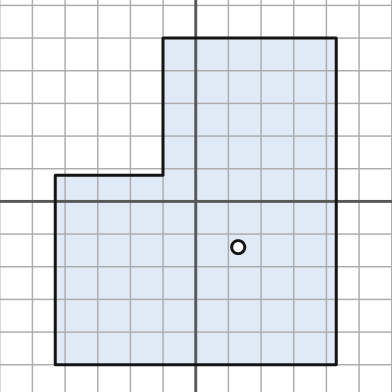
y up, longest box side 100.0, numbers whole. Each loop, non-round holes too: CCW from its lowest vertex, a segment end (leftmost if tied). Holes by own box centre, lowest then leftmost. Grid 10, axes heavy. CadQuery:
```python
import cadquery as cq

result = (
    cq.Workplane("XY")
    .moveTo(-43.0, -50.0)
    .lineTo(43.0, -50.0)
    .lineTo(43.0, 50.0)
    .lineTo(-10.0, 50.0)
    .lineTo(-10.0, 8.0)
    .lineTo(-43.0, 8.0)
    .close()
    .moveTo(13.0, -14.0)
    .circle(2.0)
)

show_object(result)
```